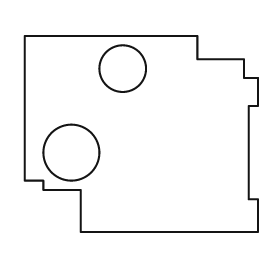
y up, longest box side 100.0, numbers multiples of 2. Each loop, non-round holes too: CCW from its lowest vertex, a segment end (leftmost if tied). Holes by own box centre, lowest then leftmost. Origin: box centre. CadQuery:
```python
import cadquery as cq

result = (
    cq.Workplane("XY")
    .moveTo(-26.0, -42.0)
    .lineTo(50.0, -42.0)
    .lineTo(50.0, -28.0)
    .lineTo(46.0, -28.0)
    .lineTo(46.0, 12.0)
    .lineTo(50.0, 12.0)
    .lineTo(50.0, 24.0)
    .lineTo(44.0, 24.0)
    .lineTo(44.0, 32.0)
    .lineTo(24.0, 32.0)
    .lineTo(24.0, 42.0)
    .lineTo(-50.0, 42.0)
    .lineTo(-50.0, -20.0)
    .lineTo(-42.0, -20.0)
    .lineTo(-42.0, -24.0)
    .lineTo(-26.0, -24.0)
    .close()
    .moveTo(-30.0, -8.0)
    .circle(12.0)
    .moveTo(-8.0, 28.0)
    .circle(10.0)
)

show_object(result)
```